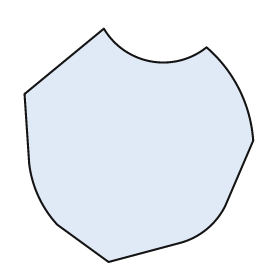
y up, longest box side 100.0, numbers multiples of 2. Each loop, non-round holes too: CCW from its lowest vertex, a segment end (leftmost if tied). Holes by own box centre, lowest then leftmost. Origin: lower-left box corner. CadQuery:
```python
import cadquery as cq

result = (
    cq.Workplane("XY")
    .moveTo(36.0, 0.0)
    .lineTo(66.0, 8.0)
    .threePointArc((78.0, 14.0), (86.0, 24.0))
    .lineTo(98.0, 52.0)
    .threePointArc((92.0, 74.0), (78.0, 92.0))
    .threePointArc((54.0, 86.0), (34.0, 100.0))
    .lineTo(0.0, 72.0)
    .lineTo(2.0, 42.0)
    .threePointArc((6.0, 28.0), (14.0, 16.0))
    .close()
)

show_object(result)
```